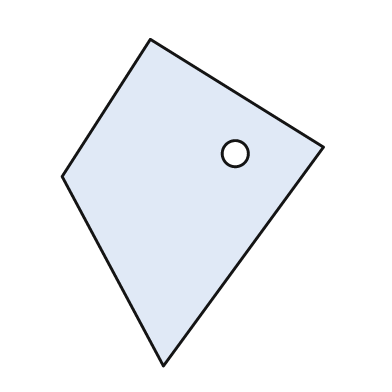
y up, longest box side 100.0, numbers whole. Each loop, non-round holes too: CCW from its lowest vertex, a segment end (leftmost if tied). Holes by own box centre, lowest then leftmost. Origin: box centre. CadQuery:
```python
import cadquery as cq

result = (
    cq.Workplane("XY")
    .moveTo(-9.0, -50.0)
    .lineTo(40.0, 17.0)
    .lineTo(-13.0, 50.0)
    .lineTo(-40.0, 8.0)
    .close()
    .moveTo(13.0, 15.0)
    .circle(4.0)
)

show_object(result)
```